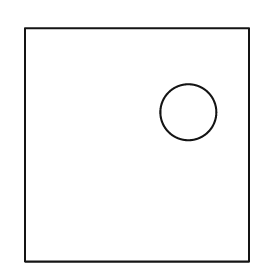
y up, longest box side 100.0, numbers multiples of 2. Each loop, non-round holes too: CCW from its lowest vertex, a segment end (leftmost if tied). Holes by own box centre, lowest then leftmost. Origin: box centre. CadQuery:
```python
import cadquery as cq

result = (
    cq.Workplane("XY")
    .moveTo(-48.0, -50.0)
    .lineTo(48.0, -50.0)
    .lineTo(48.0, 50.0)
    .lineTo(-48.0, 50.0)
    .close()
    .moveTo(22.0, 14.0)
    .circle(12.0)
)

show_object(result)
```